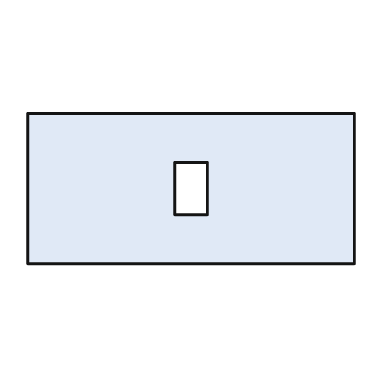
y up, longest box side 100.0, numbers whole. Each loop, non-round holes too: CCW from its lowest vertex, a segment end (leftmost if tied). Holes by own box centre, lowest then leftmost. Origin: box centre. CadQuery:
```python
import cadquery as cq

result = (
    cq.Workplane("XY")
    .moveTo(-50.0, -23.0)
    .lineTo(50.0, -23.0)
    .lineTo(50.0, 23.0)
    .lineTo(-50.0, 23.0)
    .close()
    .moveTo(-5.0, -8.0)
    .lineTo(5.0, -8.0)
    .lineTo(5.0, 8.0)
    .lineTo(-5.0, 8.0)
    .close()
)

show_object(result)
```